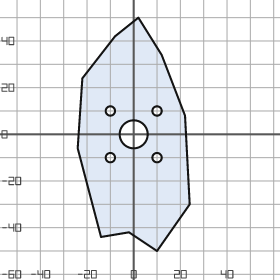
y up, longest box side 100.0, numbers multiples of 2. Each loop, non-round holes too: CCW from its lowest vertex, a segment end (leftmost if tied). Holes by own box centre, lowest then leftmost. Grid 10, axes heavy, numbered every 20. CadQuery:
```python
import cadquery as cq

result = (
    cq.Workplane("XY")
    .moveTo(10.0, -50.0)
    .lineTo(24.0, -30.0)
    .lineTo(22.0, 8.0)
    .lineTo(12.0, 34.0)
    .lineTo(2.0, 50.0)
    .lineTo(-8.0, 42.0)
    .lineTo(-22.0, 24.0)
    .lineTo(-24.0, -6.0)
    .lineTo(-14.0, -44.0)
    .lineTo(-2.0, -42.0)
    .close()
    .moveTo(-10.0, -10.0)
    .circle(2.0)
    .moveTo(10.0, -10.0)
    .circle(2.0)
    .moveTo(0.0, 0.0)
    .circle(6.0)
    .moveTo(-10.0, 10.0)
    .circle(2.0)
    .moveTo(10.0, 10.0)
    .circle(2.0)
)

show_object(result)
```